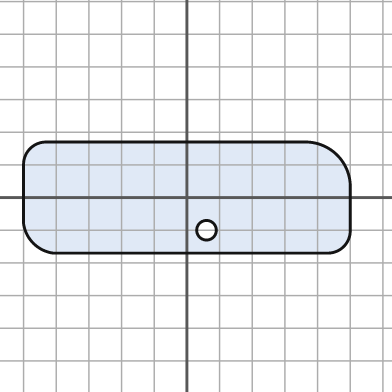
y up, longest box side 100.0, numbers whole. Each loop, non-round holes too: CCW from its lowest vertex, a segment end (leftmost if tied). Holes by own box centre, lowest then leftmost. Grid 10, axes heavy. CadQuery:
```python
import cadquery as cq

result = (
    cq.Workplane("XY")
    .moveTo(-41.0, -17.0)
    .lineTo(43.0, -17.0)
    .threePointArc((48.0, -15.0), (50.0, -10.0))
    .lineTo(50.0, 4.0)
    .threePointArc((46.0, 13.0), (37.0, 17.0))
    .lineTo(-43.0, 17.0)
    .threePointArc((-48.0, 15.0), (-50.0, 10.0))
    .lineTo(-50.0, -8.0)
    .threePointArc((-47.0, -14.0), (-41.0, -17.0))
    .close()
    .moveTo(6.0, -10.0)
    .circle(3.0)
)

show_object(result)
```